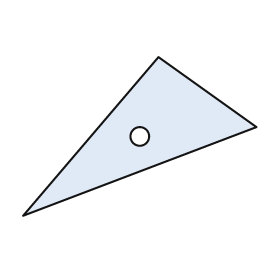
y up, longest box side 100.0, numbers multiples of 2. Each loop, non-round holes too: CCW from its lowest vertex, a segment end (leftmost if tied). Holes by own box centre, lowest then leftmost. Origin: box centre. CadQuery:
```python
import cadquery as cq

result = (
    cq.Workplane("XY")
    .moveTo(-50.0, -34.0)
    .lineTo(50.0, 4.0)
    .lineTo(8.0, 34.0)
    .close()
    .moveTo(0.0, 0.0)
    .circle(4.0)
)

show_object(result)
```